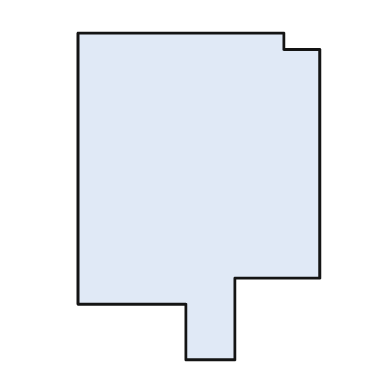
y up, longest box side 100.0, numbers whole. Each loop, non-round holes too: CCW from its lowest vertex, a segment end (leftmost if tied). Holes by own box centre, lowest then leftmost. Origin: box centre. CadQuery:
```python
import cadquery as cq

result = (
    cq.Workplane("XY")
    .moveTo(-4.0, -50.0)
    .lineTo(11.0, -50.0)
    .lineTo(11.0, -25.0)
    .lineTo(37.0, -25.0)
    .lineTo(37.0, 45.0)
    .lineTo(26.0, 45.0)
    .lineTo(26.0, 50.0)
    .lineTo(-37.0, 50.0)
    .lineTo(-37.0, -33.0)
    .lineTo(-4.0, -33.0)
    .close()
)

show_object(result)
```